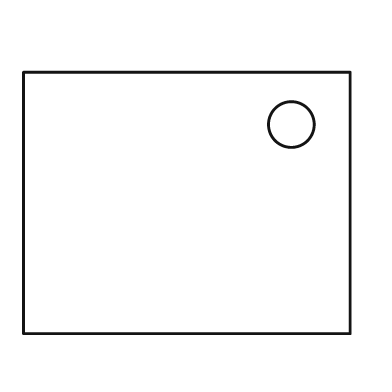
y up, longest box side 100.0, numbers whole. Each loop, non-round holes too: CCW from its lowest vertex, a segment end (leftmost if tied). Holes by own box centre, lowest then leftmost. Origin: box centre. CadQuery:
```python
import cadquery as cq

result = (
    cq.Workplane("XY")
    .moveTo(-50.0, -40.0)
    .lineTo(50.0, -40.0)
    .lineTo(50.0, 40.0)
    .lineTo(-50.0, 40.0)
    .close()
    .moveTo(32.0, 24.0)
    .circle(7.0)
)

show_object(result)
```